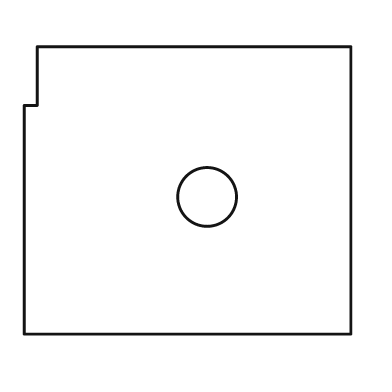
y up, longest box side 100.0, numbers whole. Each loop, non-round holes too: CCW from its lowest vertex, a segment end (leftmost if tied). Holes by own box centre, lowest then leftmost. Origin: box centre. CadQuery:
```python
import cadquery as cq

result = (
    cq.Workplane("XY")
    .moveTo(-50.0, -44.0)
    .lineTo(50.0, -44.0)
    .lineTo(50.0, 44.0)
    .lineTo(-46.0, 44.0)
    .lineTo(-46.0, 26.0)
    .lineTo(-50.0, 26.0)
    .close()
    .moveTo(6.0, -2.0)
    .circle(9.0)
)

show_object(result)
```